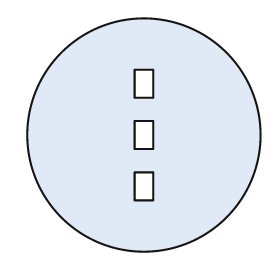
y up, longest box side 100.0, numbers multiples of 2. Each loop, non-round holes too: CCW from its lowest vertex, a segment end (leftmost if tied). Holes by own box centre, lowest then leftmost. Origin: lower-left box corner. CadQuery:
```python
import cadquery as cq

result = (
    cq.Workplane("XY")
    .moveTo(50.0, 50.0)
    .circle(50.0)
    .moveTo(46.0, 22.0)
    .lineTo(54.0, 22.0)
    .lineTo(54.0, 34.0)
    .lineTo(46.0, 34.0)
    .close()
    .moveTo(46.0, 44.0)
    .lineTo(54.0, 44.0)
    .lineTo(54.0, 56.0)
    .lineTo(46.0, 56.0)
    .close()
    .moveTo(46.0, 66.0)
    .lineTo(54.0, 66.0)
    .lineTo(54.0, 78.0)
    .lineTo(46.0, 78.0)
    .close()
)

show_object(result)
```